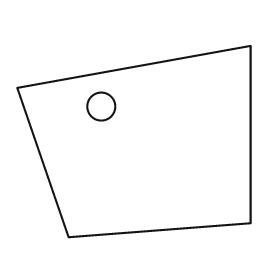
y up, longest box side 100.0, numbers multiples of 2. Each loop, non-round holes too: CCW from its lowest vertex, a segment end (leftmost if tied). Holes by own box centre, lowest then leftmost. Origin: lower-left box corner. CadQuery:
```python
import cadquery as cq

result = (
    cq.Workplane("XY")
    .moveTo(22.0, 0.0)
    .lineTo(100.0, 6.0)
    .lineTo(100.0, 82.0)
    .lineTo(0.0, 64.0)
    .close()
    .moveTo(36.0, 56.0)
    .circle(6.0)
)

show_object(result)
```